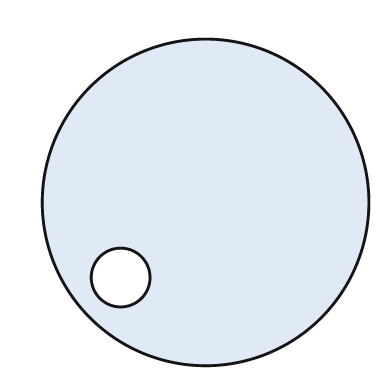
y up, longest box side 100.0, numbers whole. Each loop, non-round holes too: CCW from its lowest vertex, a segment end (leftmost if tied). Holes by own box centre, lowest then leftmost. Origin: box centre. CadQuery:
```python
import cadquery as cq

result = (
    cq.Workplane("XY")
    .moveTo(0.0, 0.0)
    .circle(50.0)
    .moveTo(-26.0, -23.0)
    .circle(9.0)
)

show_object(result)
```